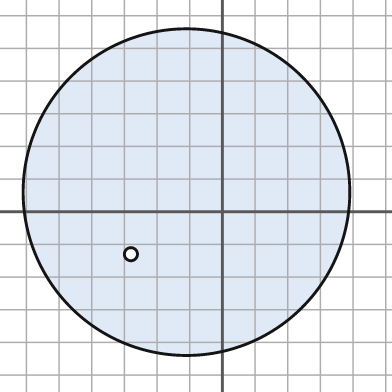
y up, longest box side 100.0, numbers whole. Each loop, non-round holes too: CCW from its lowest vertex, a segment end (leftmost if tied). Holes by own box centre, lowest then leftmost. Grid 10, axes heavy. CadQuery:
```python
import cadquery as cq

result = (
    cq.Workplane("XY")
    .moveTo(-11.0, 6.0)
    .circle(50.0)
    .moveTo(-28.0, -13.0)
    .circle(2.0)
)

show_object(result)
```